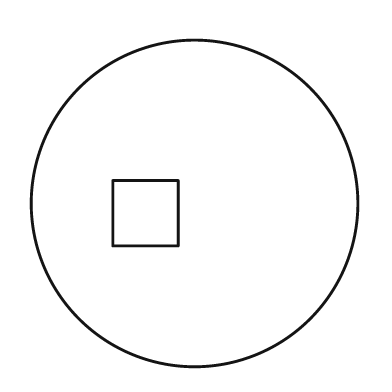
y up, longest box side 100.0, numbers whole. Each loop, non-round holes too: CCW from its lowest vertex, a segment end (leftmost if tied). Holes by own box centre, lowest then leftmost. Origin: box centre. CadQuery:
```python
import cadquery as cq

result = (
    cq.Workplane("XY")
    .moveTo(0.0, 0.0)
    .circle(50.0)
    .moveTo(-25.0, -13.0)
    .lineTo(-5.0, -13.0)
    .lineTo(-5.0, 7.0)
    .lineTo(-25.0, 7.0)
    .close()
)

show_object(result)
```